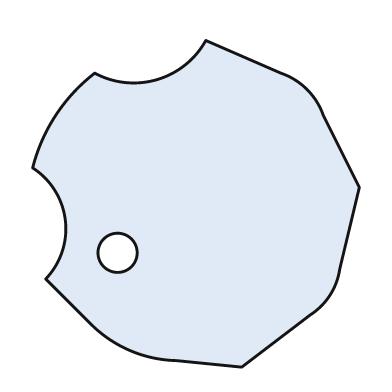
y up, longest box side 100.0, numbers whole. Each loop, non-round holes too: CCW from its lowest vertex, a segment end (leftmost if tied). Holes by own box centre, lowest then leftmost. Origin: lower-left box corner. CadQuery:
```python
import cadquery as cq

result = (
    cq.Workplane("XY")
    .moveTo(64.0, 0.0)
    .lineTo(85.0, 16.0)
    .threePointArc((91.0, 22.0), (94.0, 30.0))
    .lineTo(100.0, 55.0)
    .lineTo(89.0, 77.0)
    .threePointArc((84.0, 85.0), (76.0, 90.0))
    .lineTo(53.0, 100.0)
    .threePointArc((38.0, 88.0), (19.0, 90.0))
    .threePointArc((7.0, 77.0), (0.0, 61.0))
    .threePointArc((10.0, 45.0), (4.0, 27.0))
    .lineTo(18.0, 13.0)
    .threePointArc((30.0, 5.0), (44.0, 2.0))
    .close()
    .moveTo(26.0, 35.0)
    .circle(6.0)
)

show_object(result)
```